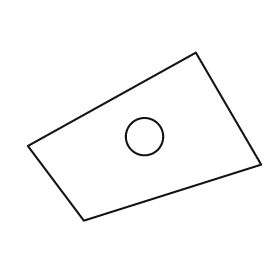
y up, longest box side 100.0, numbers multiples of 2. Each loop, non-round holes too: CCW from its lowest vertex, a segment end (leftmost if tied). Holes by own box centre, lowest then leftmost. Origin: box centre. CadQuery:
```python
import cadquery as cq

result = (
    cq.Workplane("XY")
    .moveTo(-26.0, -36.0)
    .lineTo(50.0, -12.0)
    .lineTo(22.0, 36.0)
    .lineTo(-50.0, -4.0)
    .close()
    .moveTo(0.0, 0.0)
    .circle(8.0)
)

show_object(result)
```